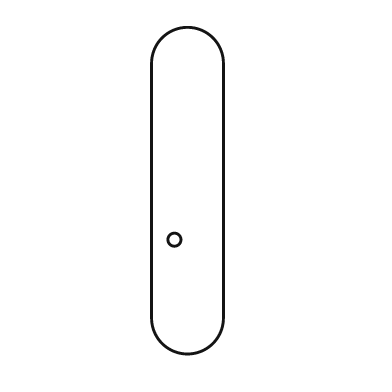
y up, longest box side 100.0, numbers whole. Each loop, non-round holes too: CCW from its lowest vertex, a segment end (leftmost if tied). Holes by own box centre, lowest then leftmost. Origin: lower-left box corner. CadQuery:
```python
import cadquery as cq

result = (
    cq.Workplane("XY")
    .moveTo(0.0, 11.0)
    .threePointArc((11.0, 0.0), (22.0, 11.0))
    .lineTo(22.0, 89.0)
    .threePointArc((11.0, 100.0), (0.0, 89.0))
    .close()
    .moveTo(7.0, 35.0)
    .circle(2.0)
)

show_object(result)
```